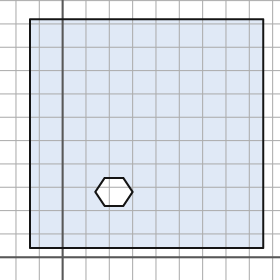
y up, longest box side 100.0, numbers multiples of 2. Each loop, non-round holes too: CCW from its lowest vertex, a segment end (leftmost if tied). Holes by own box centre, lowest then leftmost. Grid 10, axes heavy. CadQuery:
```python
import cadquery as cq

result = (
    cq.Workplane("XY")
    .moveTo(-14.0, 4.0)
    .lineTo(86.0, 4.0)
    .lineTo(86.0, 102.0)
    .lineTo(-14.0, 102.0)
    .close()
    .moveTo(18.0, 22.0)
    .lineTo(26.0, 22.0)
    .lineTo(30.0, 28.0)
    .lineTo(26.0, 34.0)
    .lineTo(18.0, 34.0)
    .lineTo(14.0, 28.0)
    .close()
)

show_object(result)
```